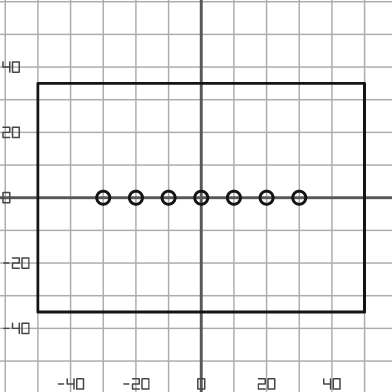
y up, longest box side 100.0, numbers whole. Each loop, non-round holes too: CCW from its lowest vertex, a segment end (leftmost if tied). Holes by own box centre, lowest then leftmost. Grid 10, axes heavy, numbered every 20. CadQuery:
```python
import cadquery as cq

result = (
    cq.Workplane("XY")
    .moveTo(-50.0, -35.0)
    .lineTo(50.0, -35.0)
    .lineTo(50.0, 35.0)
    .lineTo(-50.0, 35.0)
    .close()
    .moveTo(-30.0, 0.0)
    .circle(2.0)
    .moveTo(-20.0, 0.0)
    .circle(2.0)
    .moveTo(-10.0, 0.0)
    .circle(2.0)
    .moveTo(0.0, 0.0)
    .circle(2.0)
    .moveTo(10.0, 0.0)
    .circle(2.0)
    .moveTo(20.0, 0.0)
    .circle(2.0)
    .moveTo(30.0, 0.0)
    .circle(2.0)
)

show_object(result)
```